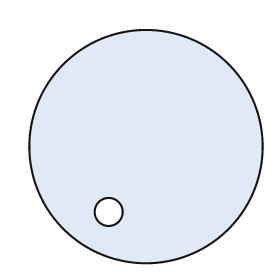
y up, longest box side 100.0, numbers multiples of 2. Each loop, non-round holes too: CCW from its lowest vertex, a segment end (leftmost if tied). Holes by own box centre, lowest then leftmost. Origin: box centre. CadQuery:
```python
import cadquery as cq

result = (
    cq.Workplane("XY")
    .moveTo(0.0, 0.0)
    .circle(50.0)
    .moveTo(-16.0, -28.0)
    .circle(6.0)
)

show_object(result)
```